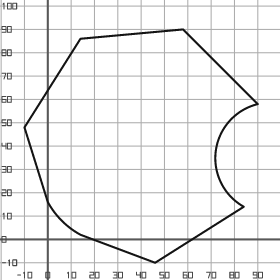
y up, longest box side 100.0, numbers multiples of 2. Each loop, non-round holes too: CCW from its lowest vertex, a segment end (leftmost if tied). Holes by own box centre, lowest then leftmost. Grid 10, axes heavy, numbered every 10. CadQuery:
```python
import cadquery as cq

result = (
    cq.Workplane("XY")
    .moveTo(46.0, -10.0)
    .lineTo(84.0, 14.0)
    .threePointArc((72.0, 38.0), (90.0, 58.0))
    .lineTo(58.0, 90.0)
    .lineTo(14.0, 86.0)
    .lineTo(-10.0, 48.0)
    .lineTo(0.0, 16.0)
    .threePointArc((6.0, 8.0), (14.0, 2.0))
    .close()
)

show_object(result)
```